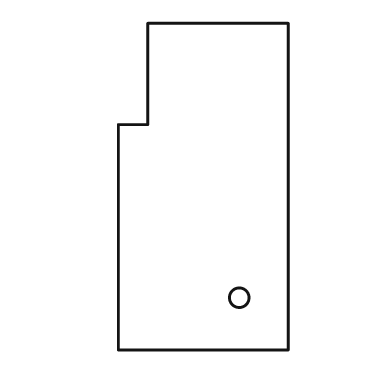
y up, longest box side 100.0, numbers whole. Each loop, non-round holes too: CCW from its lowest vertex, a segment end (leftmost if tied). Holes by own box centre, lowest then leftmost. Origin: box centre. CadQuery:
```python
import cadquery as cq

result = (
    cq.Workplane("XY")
    .moveTo(-26.0, -50.0)
    .lineTo(26.0, -50.0)
    .lineTo(26.0, 50.0)
    .lineTo(-17.0, 50.0)
    .lineTo(-17.0, 19.0)
    .lineTo(-26.0, 19.0)
    .close()
    .moveTo(11.0, -34.0)
    .circle(3.0)
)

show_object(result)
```